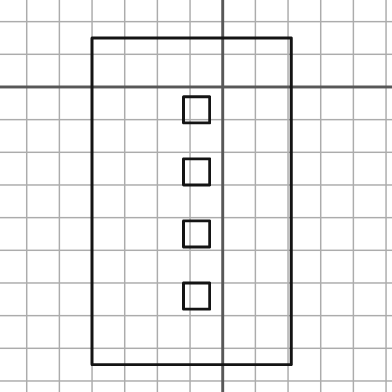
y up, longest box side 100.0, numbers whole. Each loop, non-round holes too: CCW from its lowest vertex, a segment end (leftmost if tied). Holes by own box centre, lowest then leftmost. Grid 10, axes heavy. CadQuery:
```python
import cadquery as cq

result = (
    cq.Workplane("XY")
    .moveTo(-40.0, -85.0)
    .lineTo(21.0, -85.0)
    .lineTo(21.0, 15.0)
    .lineTo(-40.0, 15.0)
    .close()
    .moveTo(-12.0, -68.0)
    .lineTo(-4.0, -68.0)
    .lineTo(-4.0, -60.0)
    .lineTo(-12.0, -60.0)
    .close()
    .moveTo(-12.0, -49.0)
    .lineTo(-4.0, -49.0)
    .lineTo(-4.0, -41.0)
    .lineTo(-12.0, -41.0)
    .close()
    .moveTo(-12.0, -30.0)
    .lineTo(-4.0, -30.0)
    .lineTo(-4.0, -22.0)
    .lineTo(-12.0, -22.0)
    .close()
    .moveTo(-12.0, -11.0)
    .lineTo(-4.0, -11.0)
    .lineTo(-4.0, -3.0)
    .lineTo(-12.0, -3.0)
    .close()
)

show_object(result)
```